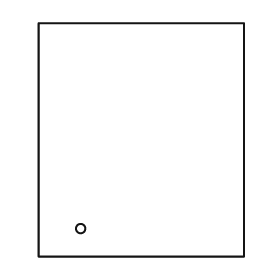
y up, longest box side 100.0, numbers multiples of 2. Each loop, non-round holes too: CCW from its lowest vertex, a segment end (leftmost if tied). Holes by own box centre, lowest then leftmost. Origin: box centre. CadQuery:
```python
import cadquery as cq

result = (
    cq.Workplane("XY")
    .moveTo(-44.0, -50.0)
    .lineTo(44.0, -50.0)
    .lineTo(44.0, 50.0)
    .lineTo(-44.0, 50.0)
    .close()
    .moveTo(-26.0, -38.0)
    .circle(2.0)
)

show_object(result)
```